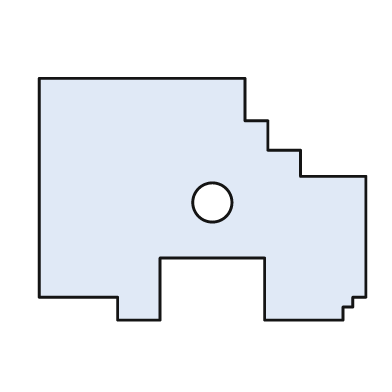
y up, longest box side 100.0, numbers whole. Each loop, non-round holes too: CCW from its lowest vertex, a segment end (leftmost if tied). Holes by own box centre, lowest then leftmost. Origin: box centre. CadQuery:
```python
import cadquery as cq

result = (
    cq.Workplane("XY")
    .moveTo(-26.0, -37.0)
    .lineTo(-13.0, -37.0)
    .lineTo(-13.0, -18.0)
    .lineTo(19.0, -18.0)
    .lineTo(19.0, -37.0)
    .lineTo(43.0, -37.0)
    .lineTo(43.0, -33.0)
    .lineTo(46.0, -33.0)
    .lineTo(46.0, -30.0)
    .lineTo(50.0, -30.0)
    .lineTo(50.0, 7.0)
    .lineTo(30.0, 7.0)
    .lineTo(30.0, 15.0)
    .lineTo(20.0, 15.0)
    .lineTo(20.0, 24.0)
    .lineTo(13.0, 24.0)
    .lineTo(13.0, 37.0)
    .lineTo(-50.0, 37.0)
    .lineTo(-50.0, -30.0)
    .lineTo(-26.0, -30.0)
    .close()
    .moveTo(3.0, -1.0)
    .circle(6.0)
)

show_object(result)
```